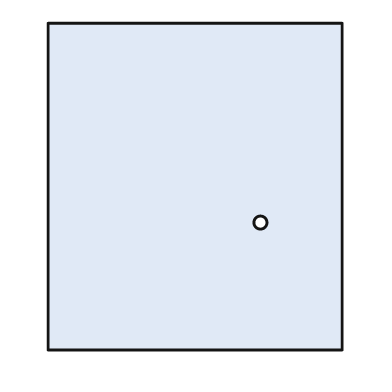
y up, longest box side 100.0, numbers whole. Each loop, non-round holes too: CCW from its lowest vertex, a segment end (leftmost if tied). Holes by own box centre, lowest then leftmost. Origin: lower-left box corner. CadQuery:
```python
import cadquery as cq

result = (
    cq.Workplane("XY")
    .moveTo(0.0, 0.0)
    .lineTo(90.0, 0.0)
    .lineTo(90.0, 100.0)
    .lineTo(0.0, 100.0)
    .close()
    .moveTo(65.0, 39.0)
    .circle(2.0)
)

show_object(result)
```